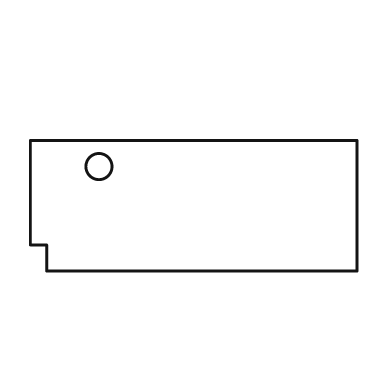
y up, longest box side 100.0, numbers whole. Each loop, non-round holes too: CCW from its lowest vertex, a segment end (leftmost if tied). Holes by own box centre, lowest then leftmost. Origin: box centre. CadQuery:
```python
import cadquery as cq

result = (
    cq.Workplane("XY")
    .moveTo(-45.0, -20.0)
    .lineTo(50.0, -20.0)
    .lineTo(50.0, 20.0)
    .lineTo(-50.0, 20.0)
    .lineTo(-50.0, -12.0)
    .lineTo(-45.0, -12.0)
    .close()
    .moveTo(-29.0, 12.0)
    .circle(4.0)
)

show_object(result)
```